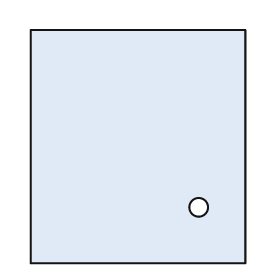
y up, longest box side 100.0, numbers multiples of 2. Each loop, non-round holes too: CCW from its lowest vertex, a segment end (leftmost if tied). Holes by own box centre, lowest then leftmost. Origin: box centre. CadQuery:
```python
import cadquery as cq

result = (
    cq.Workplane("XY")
    .moveTo(-46.0, -50.0)
    .lineTo(46.0, -50.0)
    .lineTo(46.0, 50.0)
    .lineTo(-46.0, 50.0)
    .close()
    .moveTo(26.0, -26.0)
    .circle(4.0)
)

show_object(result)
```